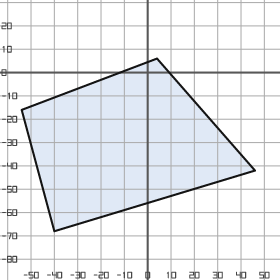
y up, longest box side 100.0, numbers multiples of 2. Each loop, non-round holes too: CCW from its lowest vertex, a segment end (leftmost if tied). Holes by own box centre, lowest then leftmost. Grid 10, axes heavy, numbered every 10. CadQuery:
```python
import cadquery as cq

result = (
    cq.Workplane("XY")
    .moveTo(-40.0, -68.0)
    .lineTo(46.0, -42.0)
    .lineTo(4.0, 6.0)
    .lineTo(-54.0, -16.0)
    .close()
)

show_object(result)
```